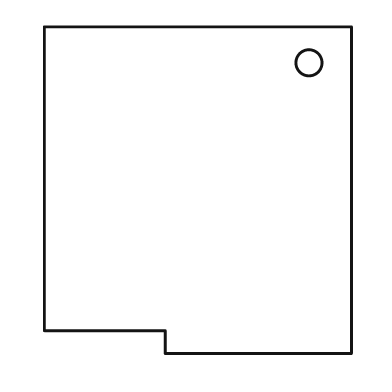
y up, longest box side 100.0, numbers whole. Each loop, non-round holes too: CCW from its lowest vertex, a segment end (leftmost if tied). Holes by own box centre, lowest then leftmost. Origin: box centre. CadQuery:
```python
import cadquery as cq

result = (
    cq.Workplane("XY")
    .moveTo(-10.0, -50.0)
    .lineTo(47.0, -50.0)
    .lineTo(47.0, 50.0)
    .lineTo(-47.0, 50.0)
    .lineTo(-47.0, -43.0)
    .lineTo(-10.0, -43.0)
    .close()
    .moveTo(34.0, 39.0)
    .circle(4.0)
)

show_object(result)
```